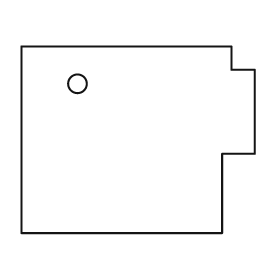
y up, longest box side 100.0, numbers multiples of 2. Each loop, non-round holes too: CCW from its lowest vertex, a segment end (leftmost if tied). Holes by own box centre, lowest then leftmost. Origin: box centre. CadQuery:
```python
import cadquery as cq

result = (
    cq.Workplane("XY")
    .moveTo(-50.0, -40.0)
    .lineTo(36.0, -40.0)
    .lineTo(36.0, -6.0)
    .lineTo(50.0, -6.0)
    .lineTo(50.0, 30.0)
    .lineTo(40.0, 30.0)
    .lineTo(40.0, 40.0)
    .lineTo(-50.0, 40.0)
    .close()
    .moveTo(-26.0, 24.0)
    .circle(4.0)
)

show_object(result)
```